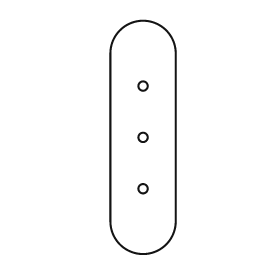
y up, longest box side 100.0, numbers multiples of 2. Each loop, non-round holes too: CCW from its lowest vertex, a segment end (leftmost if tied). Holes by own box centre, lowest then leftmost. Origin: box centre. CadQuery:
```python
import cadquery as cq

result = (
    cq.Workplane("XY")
    .moveTo(-14.0, -36.0)
    .threePointArc((0.0, -50.0), (14.0, -36.0))
    .lineTo(14.0, 36.0)
    .threePointArc((0.0, 50.0), (-14.0, 36.0))
    .close()
    .moveTo(0.0, -22.0)
    .circle(2.0)
    .moveTo(0.0, 0.0)
    .circle(2.0)
    .moveTo(0.0, 22.0)
    .circle(2.0)
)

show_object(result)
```